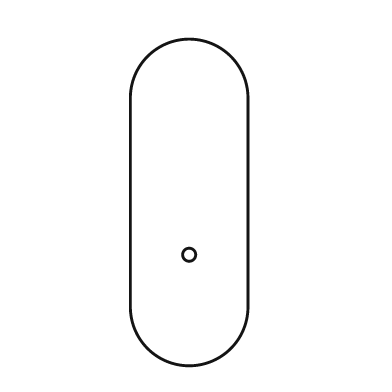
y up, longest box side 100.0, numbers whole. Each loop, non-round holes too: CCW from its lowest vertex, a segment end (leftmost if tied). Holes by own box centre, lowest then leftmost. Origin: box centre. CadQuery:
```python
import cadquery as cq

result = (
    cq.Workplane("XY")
    .moveTo(-18.0, -32.0)
    .threePointArc((0.0, -50.0), (18.0, -32.0))
    .lineTo(18.0, 32.0)
    .threePointArc((0.0, 50.0), (-18.0, 32.0))
    .close()
    .moveTo(0.0, -16.0)
    .circle(2.0)
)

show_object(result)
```